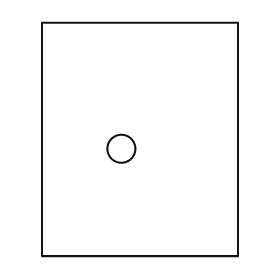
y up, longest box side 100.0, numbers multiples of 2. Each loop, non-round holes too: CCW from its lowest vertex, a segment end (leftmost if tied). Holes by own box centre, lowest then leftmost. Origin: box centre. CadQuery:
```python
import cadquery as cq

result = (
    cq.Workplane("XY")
    .moveTo(-42.0, -50.0)
    .lineTo(42.0, -50.0)
    .lineTo(42.0, 50.0)
    .lineTo(-42.0, 50.0)
    .close()
    .moveTo(-8.0, -4.0)
    .circle(6.0)
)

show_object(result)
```